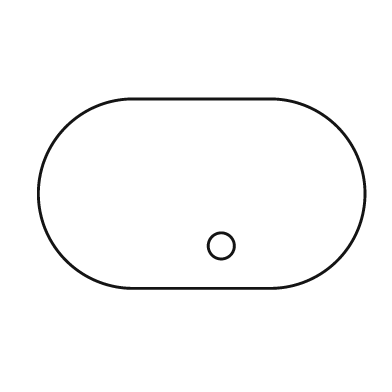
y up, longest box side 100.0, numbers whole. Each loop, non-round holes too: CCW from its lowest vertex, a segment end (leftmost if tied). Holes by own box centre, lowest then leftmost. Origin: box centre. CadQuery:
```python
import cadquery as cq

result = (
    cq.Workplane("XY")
    .moveTo(-21.0, -29.0)
    .lineTo(21.0, -29.0)
    .threePointArc((50.0, 0.0), (21.0, 29.0))
    .lineTo(-21.0, 29.0)
    .threePointArc((-50.0, 0.0), (-21.0, -29.0))
    .close()
    .moveTo(6.0, -16.0)
    .circle(4.0)
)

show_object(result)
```